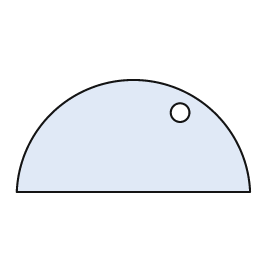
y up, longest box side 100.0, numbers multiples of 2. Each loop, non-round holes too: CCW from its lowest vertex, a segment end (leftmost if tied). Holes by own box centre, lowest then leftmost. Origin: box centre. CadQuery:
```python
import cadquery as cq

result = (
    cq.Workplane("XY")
    .moveTo(-50.0, -24.0)
    .lineTo(50.0, -24.0)
    .threePointArc((0.0, 24.0), (-50.0, -24.0))
    .close()
    .moveTo(20.0, 10.0)
    .circle(4.0)
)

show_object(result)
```